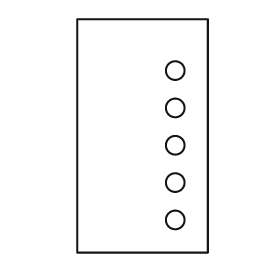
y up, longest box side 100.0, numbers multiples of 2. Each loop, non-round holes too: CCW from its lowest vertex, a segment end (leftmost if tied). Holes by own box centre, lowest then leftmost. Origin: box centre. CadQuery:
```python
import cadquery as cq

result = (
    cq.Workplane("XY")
    .moveTo(-28.0, -50.0)
    .lineTo(28.0, -50.0)
    .lineTo(28.0, 50.0)
    .lineTo(-28.0, 50.0)
    .close()
    .moveTo(14.0, -36.0)
    .circle(4.0)
    .moveTo(14.0, -20.0)
    .circle(4.0)
    .moveTo(14.0, -4.0)
    .circle(4.0)
    .moveTo(14.0, 12.0)
    .circle(4.0)
    .moveTo(14.0, 28.0)
    .circle(4.0)
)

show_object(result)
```